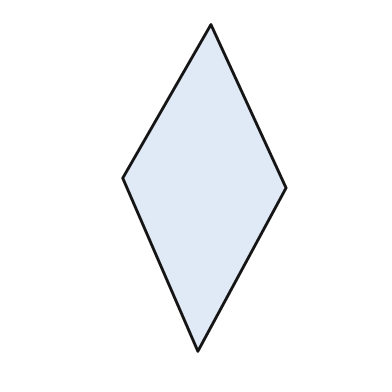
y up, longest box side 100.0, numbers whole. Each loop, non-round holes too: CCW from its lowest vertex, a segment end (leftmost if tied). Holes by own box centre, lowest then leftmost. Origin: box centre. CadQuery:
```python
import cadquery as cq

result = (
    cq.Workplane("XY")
    .moveTo(-2.0, -50.0)
    .lineTo(25.0, 0.0)
    .lineTo(2.0, 50.0)
    .lineTo(-25.0, 3.0)
    .close()
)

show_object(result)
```